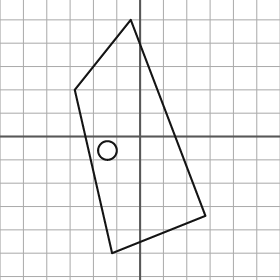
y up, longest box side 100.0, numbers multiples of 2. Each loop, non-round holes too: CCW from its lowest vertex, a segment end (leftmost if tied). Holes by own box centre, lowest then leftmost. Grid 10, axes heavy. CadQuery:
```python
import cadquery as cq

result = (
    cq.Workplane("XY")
    .moveTo(-12.0, -50.0)
    .lineTo(28.0, -34.0)
    .lineTo(-4.0, 50.0)
    .lineTo(-28.0, 20.0)
    .close()
    .moveTo(-14.0, -6.0)
    .circle(4.0)
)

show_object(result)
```